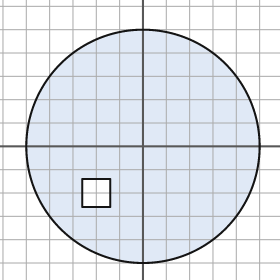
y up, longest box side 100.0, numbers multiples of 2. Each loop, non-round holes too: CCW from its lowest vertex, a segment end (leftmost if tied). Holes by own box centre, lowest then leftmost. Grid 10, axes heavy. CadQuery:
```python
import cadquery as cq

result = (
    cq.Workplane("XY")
    .moveTo(0.0, 0.0)
    .circle(50.0)
    .moveTo(-26.0, -26.0)
    .lineTo(-14.0, -26.0)
    .lineTo(-14.0, -14.0)
    .lineTo(-26.0, -14.0)
    .close()
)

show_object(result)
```